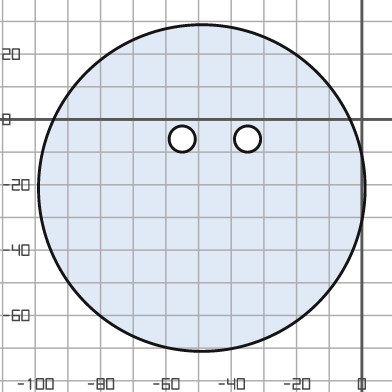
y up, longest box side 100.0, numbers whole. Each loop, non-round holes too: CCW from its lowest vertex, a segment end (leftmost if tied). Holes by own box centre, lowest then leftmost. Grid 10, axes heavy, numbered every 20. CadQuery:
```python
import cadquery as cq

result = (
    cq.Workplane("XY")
    .moveTo(-49.0, -21.0)
    .circle(50.0)
    .moveTo(-55.0, -6.0)
    .circle(4.0)
    .moveTo(-35.0, -6.0)
    .circle(4.0)
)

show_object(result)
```